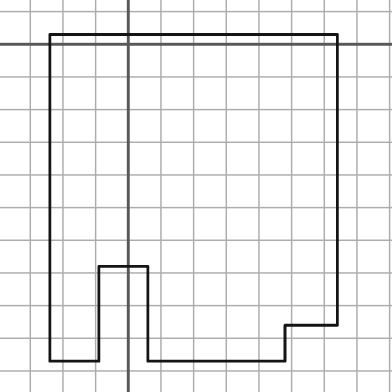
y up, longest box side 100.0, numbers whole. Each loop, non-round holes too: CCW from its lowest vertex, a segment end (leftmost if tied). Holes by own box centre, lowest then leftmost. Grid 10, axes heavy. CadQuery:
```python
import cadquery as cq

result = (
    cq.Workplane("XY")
    .moveTo(-24.0, -97.0)
    .lineTo(-9.0, -97.0)
    .lineTo(-9.0, -68.0)
    .lineTo(6.0, -68.0)
    .lineTo(6.0, -97.0)
    .lineTo(48.0, -97.0)
    .lineTo(48.0, -86.0)
    .lineTo(64.0, -86.0)
    .lineTo(64.0, 3.0)
    .lineTo(-24.0, 3.0)
    .close()
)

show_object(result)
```